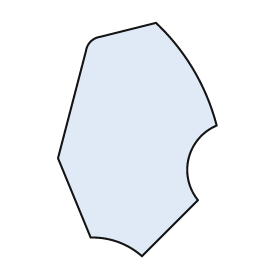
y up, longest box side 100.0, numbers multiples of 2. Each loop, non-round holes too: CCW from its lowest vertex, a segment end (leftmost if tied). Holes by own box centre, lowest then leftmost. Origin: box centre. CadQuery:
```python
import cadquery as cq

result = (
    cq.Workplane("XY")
    .moveTo(2.0, -50.0)
    .lineTo(26.0, -26.0)
    .threePointArc((22.0, -8.0), (34.0, 6.0))
    .threePointArc((24.0, 30.0), (8.0, 50.0))
    .lineTo(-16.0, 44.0)
    .threePointArc((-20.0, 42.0), (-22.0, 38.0))
    .lineTo(-34.0, -8.0)
    .lineTo(-20.0, -42.0)
    .threePointArc((-8.0, -44.0), (2.0, -50.0))
    .close()
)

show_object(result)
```